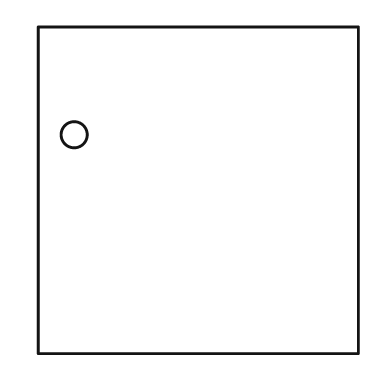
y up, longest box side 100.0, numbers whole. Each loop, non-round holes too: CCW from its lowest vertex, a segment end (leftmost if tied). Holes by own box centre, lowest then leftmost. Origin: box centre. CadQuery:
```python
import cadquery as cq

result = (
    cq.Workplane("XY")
    .moveTo(-49.0, -50.0)
    .lineTo(49.0, -50.0)
    .lineTo(49.0, 50.0)
    .lineTo(-49.0, 50.0)
    .close()
    .moveTo(-38.0, 17.0)
    .circle(4.0)
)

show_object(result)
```